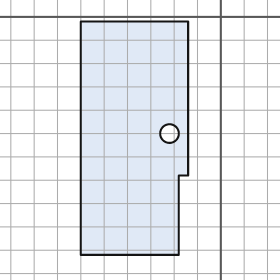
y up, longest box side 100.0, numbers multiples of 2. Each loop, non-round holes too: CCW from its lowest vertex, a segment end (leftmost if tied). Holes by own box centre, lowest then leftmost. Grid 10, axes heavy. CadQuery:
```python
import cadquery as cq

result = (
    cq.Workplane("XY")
    .moveTo(-60.0, -102.0)
    .lineTo(-18.0, -102.0)
    .lineTo(-18.0, -68.0)
    .lineTo(-14.0, -68.0)
    .lineTo(-14.0, -2.0)
    .lineTo(-60.0, -2.0)
    .close()
    .moveTo(-22.0, -50.0)
    .circle(4.0)
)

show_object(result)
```